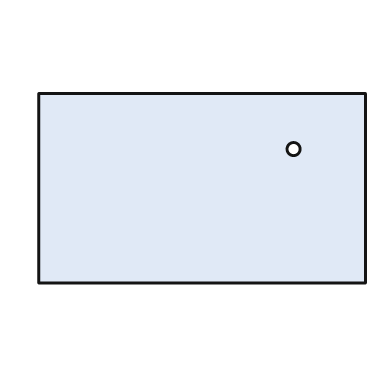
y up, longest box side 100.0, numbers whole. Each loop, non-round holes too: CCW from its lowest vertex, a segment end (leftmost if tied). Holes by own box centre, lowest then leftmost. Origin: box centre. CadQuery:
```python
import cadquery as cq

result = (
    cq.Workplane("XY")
    .moveTo(-50.0, -29.0)
    .lineTo(50.0, -29.0)
    .lineTo(50.0, 29.0)
    .lineTo(-50.0, 29.0)
    .close()
    .moveTo(28.0, 12.0)
    .circle(2.0)
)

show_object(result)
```